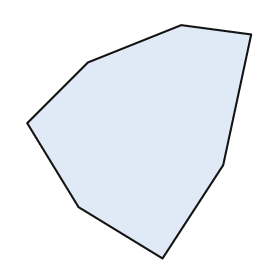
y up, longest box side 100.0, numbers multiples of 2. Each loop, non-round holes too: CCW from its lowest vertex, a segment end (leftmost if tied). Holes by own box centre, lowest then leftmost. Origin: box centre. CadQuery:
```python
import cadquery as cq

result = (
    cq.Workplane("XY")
    .moveTo(10.0, -50.0)
    .lineTo(36.0, -10.0)
    .lineTo(48.0, 46.0)
    .lineTo(18.0, 50.0)
    .lineTo(-22.0, 34.0)
    .lineTo(-48.0, 8.0)
    .lineTo(-26.0, -28.0)
    .close()
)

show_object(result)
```